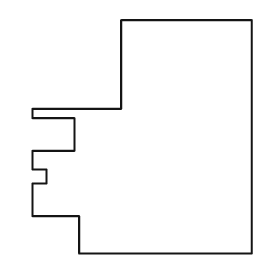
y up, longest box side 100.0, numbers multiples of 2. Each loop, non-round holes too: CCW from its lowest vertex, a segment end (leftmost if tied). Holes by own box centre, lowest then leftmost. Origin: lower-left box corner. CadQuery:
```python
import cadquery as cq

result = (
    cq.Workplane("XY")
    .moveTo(20.0, 0.0)
    .lineTo(94.0, 0.0)
    .lineTo(94.0, 100.0)
    .lineTo(38.0, 100.0)
    .lineTo(38.0, 62.0)
    .lineTo(0.0, 62.0)
    .lineTo(0.0, 58.0)
    .lineTo(18.0, 58.0)
    .lineTo(18.0, 44.0)
    .lineTo(0.0, 44.0)
    .lineTo(0.0, 36.0)
    .lineTo(6.0, 36.0)
    .lineTo(6.0, 30.0)
    .lineTo(0.0, 30.0)
    .lineTo(0.0, 16.0)
    .lineTo(20.0, 16.0)
    .close()
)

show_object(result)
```